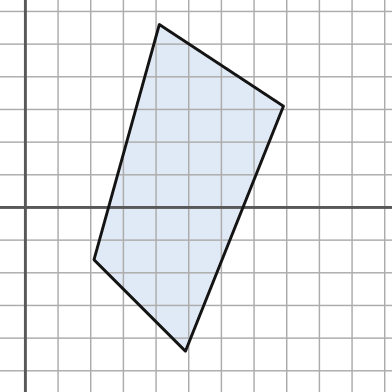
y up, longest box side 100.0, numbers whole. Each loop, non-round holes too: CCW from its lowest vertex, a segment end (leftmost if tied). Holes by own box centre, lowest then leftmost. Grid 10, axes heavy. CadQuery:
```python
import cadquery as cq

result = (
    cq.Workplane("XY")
    .moveTo(49.0, -44.0)
    .lineTo(79.0, 31.0)
    .lineTo(41.0, 56.0)
    .lineTo(21.0, -16.0)
    .close()
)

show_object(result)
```